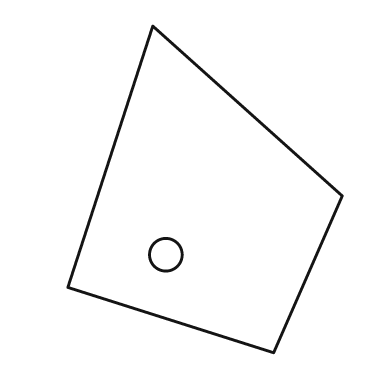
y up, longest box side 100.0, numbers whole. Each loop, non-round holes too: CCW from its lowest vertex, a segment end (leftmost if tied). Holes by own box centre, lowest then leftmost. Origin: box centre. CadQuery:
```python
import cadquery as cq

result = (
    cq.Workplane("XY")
    .moveTo(21.0, -50.0)
    .lineTo(42.0, -2.0)
    .lineTo(-16.0, 50.0)
    .lineTo(-42.0, -30.0)
    .close()
    .moveTo(-12.0, -20.0)
    .circle(5.0)
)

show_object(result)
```